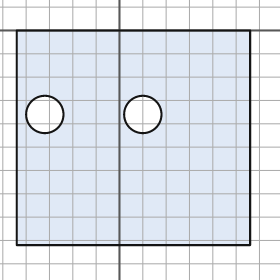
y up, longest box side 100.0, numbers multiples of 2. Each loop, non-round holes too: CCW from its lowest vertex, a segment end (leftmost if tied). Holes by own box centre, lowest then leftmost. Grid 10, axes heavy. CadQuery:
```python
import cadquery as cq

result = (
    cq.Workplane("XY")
    .moveTo(-44.0, -92.0)
    .lineTo(56.0, -92.0)
    .lineTo(56.0, 0.0)
    .lineTo(-44.0, 0.0)
    .close()
    .moveTo(-32.0, -36.0)
    .circle(8.0)
    .moveTo(10.0, -36.0)
    .circle(8.0)
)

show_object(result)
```